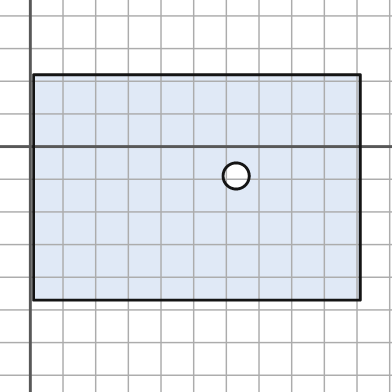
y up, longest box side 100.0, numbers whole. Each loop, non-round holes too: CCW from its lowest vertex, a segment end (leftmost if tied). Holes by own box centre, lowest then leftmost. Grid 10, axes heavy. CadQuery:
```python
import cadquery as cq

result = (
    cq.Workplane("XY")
    .moveTo(1.0, -47.0)
    .lineTo(101.0, -47.0)
    .lineTo(101.0, 22.0)
    .lineTo(1.0, 22.0)
    .close()
    .moveTo(63.0, -9.0)
    .circle(4.0)
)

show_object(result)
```